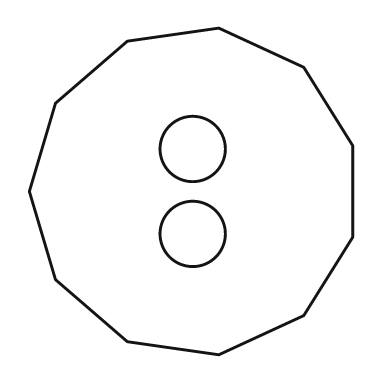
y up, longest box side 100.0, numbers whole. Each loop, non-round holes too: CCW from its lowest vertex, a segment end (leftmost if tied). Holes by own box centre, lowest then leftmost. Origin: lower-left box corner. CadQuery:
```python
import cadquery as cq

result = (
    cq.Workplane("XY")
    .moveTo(58.0, 0.0)
    .lineTo(84.0, 12.0)
    .lineTo(99.0, 36.0)
    .lineTo(99.0, 64.0)
    .lineTo(84.0, 88.0)
    .lineTo(58.0, 100.0)
    .lineTo(30.0, 96.0)
    .lineTo(8.0, 77.0)
    .lineTo(0.0, 50.0)
    .lineTo(8.0, 23.0)
    .lineTo(30.0, 4.0)
    .close()
    .moveTo(50.0, 37.0)
    .circle(10.0)
    .moveTo(50.0, 63.0)
    .circle(10.0)
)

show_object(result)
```